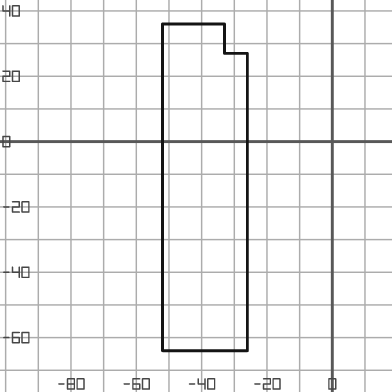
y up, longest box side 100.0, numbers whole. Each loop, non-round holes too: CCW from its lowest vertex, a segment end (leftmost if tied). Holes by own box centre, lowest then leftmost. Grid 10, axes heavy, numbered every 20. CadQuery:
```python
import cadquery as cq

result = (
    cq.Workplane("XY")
    .moveTo(-52.0, -64.0)
    .lineTo(-26.0, -64.0)
    .lineTo(-26.0, 27.0)
    .lineTo(-33.0, 27.0)
    .lineTo(-33.0, 36.0)
    .lineTo(-52.0, 36.0)
    .close()
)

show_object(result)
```